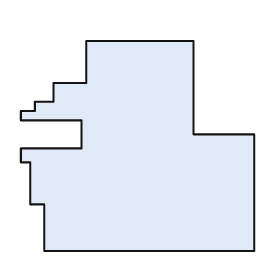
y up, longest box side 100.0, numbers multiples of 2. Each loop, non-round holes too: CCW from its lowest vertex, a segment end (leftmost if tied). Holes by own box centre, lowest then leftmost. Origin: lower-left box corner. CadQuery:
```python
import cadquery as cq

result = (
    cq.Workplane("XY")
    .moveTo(10.0, 0.0)
    .lineTo(100.0, 0.0)
    .lineTo(100.0, 50.0)
    .lineTo(74.0, 50.0)
    .lineTo(74.0, 90.0)
    .lineTo(28.0, 90.0)
    .lineTo(28.0, 72.0)
    .lineTo(14.0, 72.0)
    .lineTo(14.0, 64.0)
    .lineTo(6.0, 64.0)
    .lineTo(6.0, 60.0)
    .lineTo(0.0, 60.0)
    .lineTo(0.0, 56.0)
    .lineTo(26.0, 56.0)
    .lineTo(26.0, 44.0)
    .lineTo(0.0, 44.0)
    .lineTo(0.0, 38.0)
    .lineTo(4.0, 38.0)
    .lineTo(4.0, 20.0)
    .lineTo(10.0, 20.0)
    .close()
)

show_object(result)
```